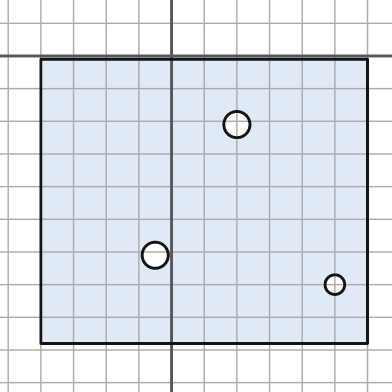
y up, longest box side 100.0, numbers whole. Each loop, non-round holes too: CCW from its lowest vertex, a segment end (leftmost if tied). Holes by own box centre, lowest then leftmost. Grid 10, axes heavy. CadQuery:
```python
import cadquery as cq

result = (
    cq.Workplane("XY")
    .moveTo(-40.0, -88.0)
    .lineTo(60.0, -88.0)
    .lineTo(60.0, -1.0)
    .lineTo(-40.0, -1.0)
    .close()
    .moveTo(50.0, -70.0)
    .circle(3.0)
    .moveTo(-5.0, -61.0)
    .circle(4.0)
    .moveTo(20.0, -21.0)
    .circle(4.0)
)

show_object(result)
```